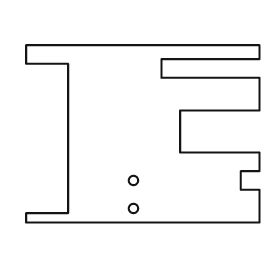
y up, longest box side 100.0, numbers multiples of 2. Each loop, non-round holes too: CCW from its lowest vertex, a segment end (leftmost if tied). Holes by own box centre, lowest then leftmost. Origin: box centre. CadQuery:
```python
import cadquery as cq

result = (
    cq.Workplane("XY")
    .moveTo(-50.0, -38.0)
    .lineTo(50.0, -38.0)
    .lineTo(50.0, -24.0)
    .lineTo(42.0, -24.0)
    .lineTo(42.0, -16.0)
    .lineTo(50.0, -16.0)
    .lineTo(50.0, -8.0)
    .lineTo(16.0, -8.0)
    .lineTo(16.0, 10.0)
    .lineTo(50.0, 10.0)
    .lineTo(50.0, 24.0)
    .lineTo(8.0, 24.0)
    .lineTo(8.0, 32.0)
    .lineTo(50.0, 32.0)
    .lineTo(50.0, 38.0)
    .lineTo(-50.0, 38.0)
    .lineTo(-50.0, 30.0)
    .lineTo(-32.0, 30.0)
    .lineTo(-32.0, -34.0)
    .lineTo(-50.0, -34.0)
    .close()
    .moveTo(-4.0, -32.0)
    .circle(2.0)
    .moveTo(-4.0, -20.0)
    .circle(2.0)
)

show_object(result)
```